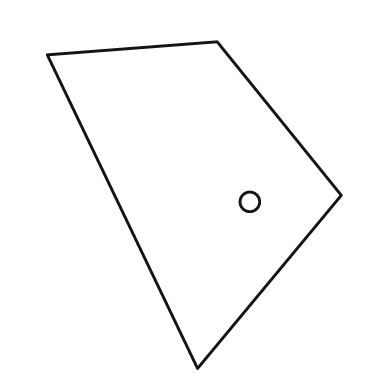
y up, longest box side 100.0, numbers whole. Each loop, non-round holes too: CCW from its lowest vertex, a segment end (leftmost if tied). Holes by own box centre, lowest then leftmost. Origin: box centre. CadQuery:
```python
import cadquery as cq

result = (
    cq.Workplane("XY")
    .moveTo(1.0, -50.0)
    .lineTo(45.0, 3.0)
    .lineTo(7.0, 50.0)
    .lineTo(-45.0, 46.0)
    .close()
    .moveTo(17.0, 1.0)
    .circle(3.0)
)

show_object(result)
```